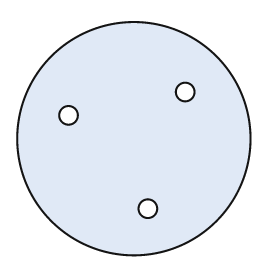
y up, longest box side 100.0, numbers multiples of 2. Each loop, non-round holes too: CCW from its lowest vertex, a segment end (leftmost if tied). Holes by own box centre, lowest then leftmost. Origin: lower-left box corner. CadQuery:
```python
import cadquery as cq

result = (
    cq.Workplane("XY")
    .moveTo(50.0, 50.0)
    .circle(50.0)
    .moveTo(56.0, 20.0)
    .circle(4.0)
    .moveTo(22.0, 60.0)
    .circle(4.0)
    .moveTo(72.0, 70.0)
    .circle(4.0)
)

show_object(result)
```